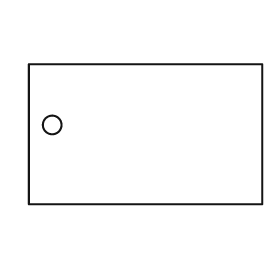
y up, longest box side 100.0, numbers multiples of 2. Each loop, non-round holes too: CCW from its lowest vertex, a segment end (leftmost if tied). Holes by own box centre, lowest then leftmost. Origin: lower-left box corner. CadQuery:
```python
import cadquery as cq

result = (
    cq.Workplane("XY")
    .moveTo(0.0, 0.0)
    .lineTo(100.0, 0.0)
    .lineTo(100.0, 60.0)
    .lineTo(0.0, 60.0)
    .close()
    .moveTo(10.0, 34.0)
    .circle(4.0)
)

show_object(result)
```